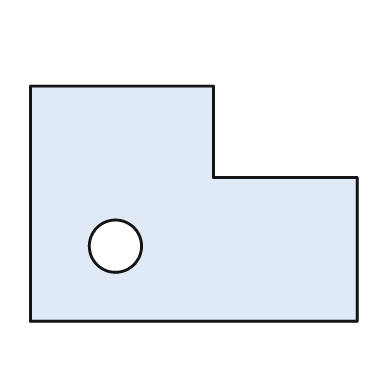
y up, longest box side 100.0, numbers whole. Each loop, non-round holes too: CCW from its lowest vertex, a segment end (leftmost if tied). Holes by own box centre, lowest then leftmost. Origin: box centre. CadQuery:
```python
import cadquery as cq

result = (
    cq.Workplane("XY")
    .moveTo(-50.0, -36.0)
    .lineTo(50.0, -36.0)
    .lineTo(50.0, 8.0)
    .lineTo(6.0, 8.0)
    .lineTo(6.0, 36.0)
    .lineTo(-50.0, 36.0)
    .close()
    .moveTo(-24.0, -13.0)
    .circle(8.0)
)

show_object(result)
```